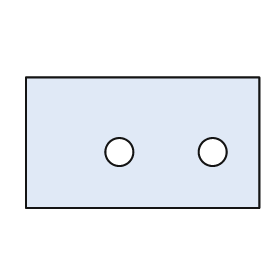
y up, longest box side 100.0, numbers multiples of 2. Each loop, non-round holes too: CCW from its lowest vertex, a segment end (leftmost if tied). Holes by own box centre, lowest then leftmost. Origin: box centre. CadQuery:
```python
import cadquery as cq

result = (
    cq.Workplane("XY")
    .moveTo(-50.0, -28.0)
    .lineTo(50.0, -28.0)
    .lineTo(50.0, 28.0)
    .lineTo(-50.0, 28.0)
    .close()
    .moveTo(-10.0, -4.0)
    .circle(6.0)
    .moveTo(30.0, -4.0)
    .circle(6.0)
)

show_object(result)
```